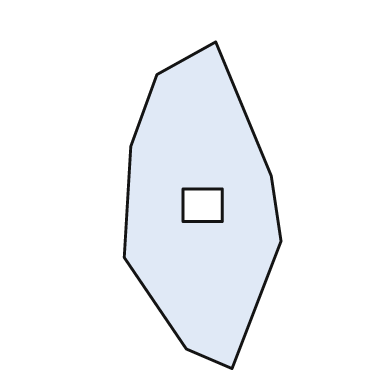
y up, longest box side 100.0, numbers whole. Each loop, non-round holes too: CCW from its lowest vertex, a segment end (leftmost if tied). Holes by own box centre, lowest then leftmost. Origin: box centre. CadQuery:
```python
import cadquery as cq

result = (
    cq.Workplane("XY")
    .moveTo(9.0, -50.0)
    .lineTo(24.0, -11.0)
    .lineTo(21.0, 9.0)
    .lineTo(4.0, 50.0)
    .lineTo(-14.0, 40.0)
    .lineTo(-22.0, 18.0)
    .lineTo(-24.0, -16.0)
    .lineTo(-5.0, -44.0)
    .close()
    .moveTo(-6.0, -5.0)
    .lineTo(6.0, -5.0)
    .lineTo(6.0, 5.0)
    .lineTo(-6.0, 5.0)
    .close()
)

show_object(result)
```